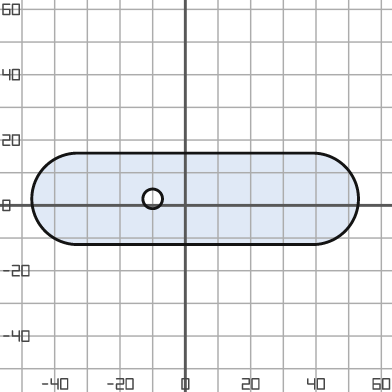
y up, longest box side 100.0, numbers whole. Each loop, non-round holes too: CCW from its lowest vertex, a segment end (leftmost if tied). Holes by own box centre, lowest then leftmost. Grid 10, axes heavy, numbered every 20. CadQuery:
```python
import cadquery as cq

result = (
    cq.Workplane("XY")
    .moveTo(-33.0, -12.0)
    .lineTo(39.0, -12.0)
    .threePointArc((53.0, 2.0), (39.0, 16.0))
    .lineTo(-33.0, 16.0)
    .threePointArc((-47.0, 2.0), (-33.0, -12.0))
    .close()
    .moveTo(-10.0, 2.0)
    .circle(3.0)
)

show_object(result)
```